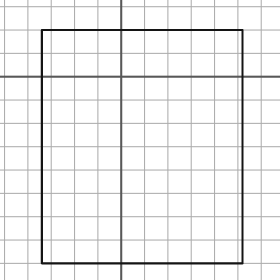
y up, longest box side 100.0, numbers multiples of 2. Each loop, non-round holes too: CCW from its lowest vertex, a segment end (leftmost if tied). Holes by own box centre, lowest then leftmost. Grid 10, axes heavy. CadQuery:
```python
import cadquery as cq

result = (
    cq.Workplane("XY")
    .moveTo(-34.0, -80.0)
    .lineTo(52.0, -80.0)
    .lineTo(52.0, 20.0)
    .lineTo(-34.0, 20.0)
    .close()
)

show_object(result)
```